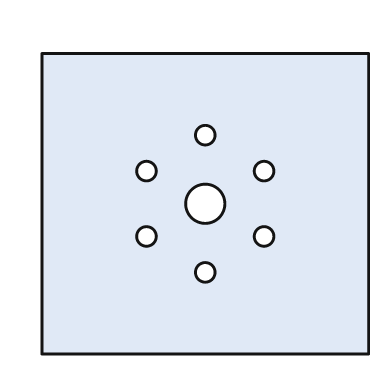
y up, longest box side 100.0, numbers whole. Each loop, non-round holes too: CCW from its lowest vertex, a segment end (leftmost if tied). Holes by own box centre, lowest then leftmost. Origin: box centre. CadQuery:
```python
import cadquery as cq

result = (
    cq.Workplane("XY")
    .moveTo(-50.0, -46.0)
    .lineTo(50.0, -46.0)
    .lineTo(50.0, 46.0)
    .lineTo(-50.0, 46.0)
    .close()
    .moveTo(0.0, -21.0)
    .circle(3.0)
    .moveTo(-18.0, -10.0)
    .circle(3.0)
    .moveTo(18.0, -10.0)
    .circle(3.0)
    .moveTo(0.0, 0.0)
    .circle(6.0)
    .moveTo(-18.0, 10.0)
    .circle(3.0)
    .moveTo(18.0, 10.0)
    .circle(3.0)
    .moveTo(0.0, 21.0)
    .circle(3.0)
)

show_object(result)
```